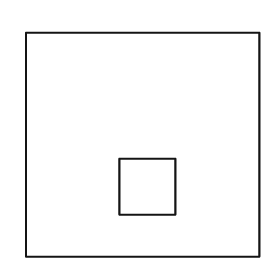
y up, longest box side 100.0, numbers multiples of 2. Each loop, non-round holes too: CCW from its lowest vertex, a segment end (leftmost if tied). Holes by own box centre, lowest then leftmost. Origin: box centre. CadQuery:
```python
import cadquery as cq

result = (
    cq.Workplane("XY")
    .moveTo(-50.0, -48.0)
    .lineTo(50.0, -48.0)
    .lineTo(50.0, 48.0)
    .lineTo(-50.0, 48.0)
    .close()
    .moveTo(-10.0, -30.0)
    .lineTo(14.0, -30.0)
    .lineTo(14.0, -6.0)
    .lineTo(-10.0, -6.0)
    .close()
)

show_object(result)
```